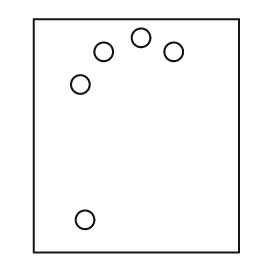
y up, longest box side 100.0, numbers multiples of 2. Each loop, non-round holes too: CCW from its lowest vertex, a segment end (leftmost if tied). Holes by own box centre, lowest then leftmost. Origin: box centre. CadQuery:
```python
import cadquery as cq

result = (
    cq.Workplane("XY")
    .moveTo(-44.0, -50.0)
    .lineTo(44.0, -50.0)
    .lineTo(44.0, 50.0)
    .lineTo(-44.0, 50.0)
    .close()
    .moveTo(-22.0, -36.0)
    .circle(4.0)
    .moveTo(-24.0, 22.0)
    .circle(4.0)
    .moveTo(-14.0, 36.0)
    .circle(4.0)
    .moveTo(16.0, 36.0)
    .circle(4.0)
    .moveTo(2.0, 42.0)
    .circle(4.0)
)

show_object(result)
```